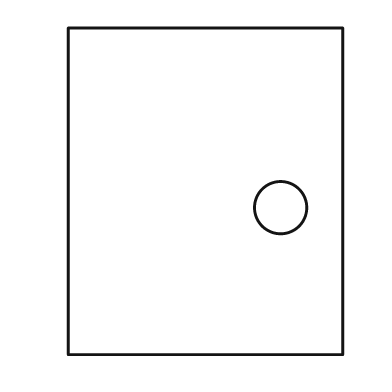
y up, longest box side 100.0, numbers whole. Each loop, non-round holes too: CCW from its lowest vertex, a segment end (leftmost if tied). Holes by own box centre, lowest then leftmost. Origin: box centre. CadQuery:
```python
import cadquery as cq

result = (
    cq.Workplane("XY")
    .moveTo(-42.0, -50.0)
    .lineTo(42.0, -50.0)
    .lineTo(42.0, 50.0)
    .lineTo(-42.0, 50.0)
    .close()
    .moveTo(23.0, -5.0)
    .circle(8.0)
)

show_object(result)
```